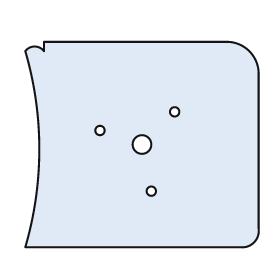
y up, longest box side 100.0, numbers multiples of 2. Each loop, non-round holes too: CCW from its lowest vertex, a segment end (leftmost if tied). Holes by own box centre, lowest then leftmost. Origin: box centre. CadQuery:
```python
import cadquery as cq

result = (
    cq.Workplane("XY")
    .moveTo(-50.0, -44.0)
    .lineTo(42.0, -44.0)
    .threePointArc((48.0, -42.0), (50.0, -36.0))
    .lineTo(50.0, 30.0)
    .threePointArc((46.0, 40.0), (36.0, 44.0))
    .lineTo(-42.0, 44.0)
    .lineTo(-42.0, 40.0)
    .threePointArc((-46.0, 42.0), (-50.0, 40.0))
    .threePointArc((-44.0, -2.0), (-50.0, -44.0))
    .close()
    .moveTo(4.0, -20.0)
    .circle(2.0)
    .moveTo(0.0, 0.0)
    .circle(4.0)
    .moveTo(-18.0, 6.0)
    .circle(2.0)
    .moveTo(14.0, 14.0)
    .circle(2.0)
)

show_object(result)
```